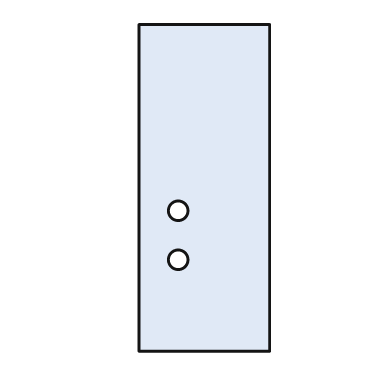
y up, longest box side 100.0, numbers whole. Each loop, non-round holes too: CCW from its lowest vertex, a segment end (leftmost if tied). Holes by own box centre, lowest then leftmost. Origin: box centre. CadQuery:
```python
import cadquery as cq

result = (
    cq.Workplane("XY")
    .moveTo(-20.0, -50.0)
    .lineTo(20.0, -50.0)
    .lineTo(20.0, 50.0)
    .lineTo(-20.0, 50.0)
    .close()
    .moveTo(-8.0, -22.0)
    .circle(3.0)
    .moveTo(-8.0, -7.0)
    .circle(3.0)
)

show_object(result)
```